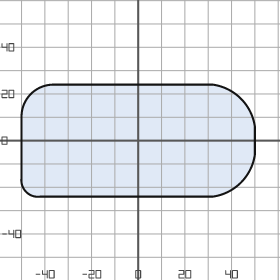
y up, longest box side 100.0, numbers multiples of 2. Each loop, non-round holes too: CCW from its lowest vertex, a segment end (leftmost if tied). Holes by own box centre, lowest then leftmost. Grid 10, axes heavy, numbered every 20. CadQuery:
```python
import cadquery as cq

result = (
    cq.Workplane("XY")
    .moveTo(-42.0, -24.0)
    .lineTo(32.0, -24.0)
    .threePointArc((44.0, -18.0), (50.0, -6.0))
    .lineTo(50.0, 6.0)
    .threePointArc((44.0, 18.0), (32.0, 24.0))
    .lineTo(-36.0, 24.0)
    .threePointArc((-46.0, 20.0), (-50.0, 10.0))
    .lineTo(-50.0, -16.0)
    .threePointArc((-48.0, -22.0), (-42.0, -24.0))
    .close()
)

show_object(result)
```